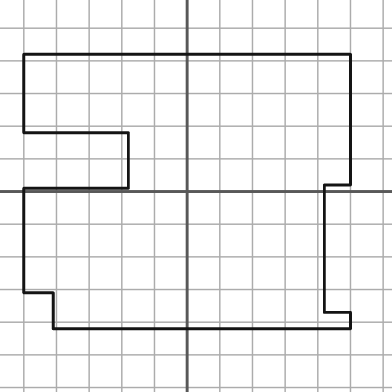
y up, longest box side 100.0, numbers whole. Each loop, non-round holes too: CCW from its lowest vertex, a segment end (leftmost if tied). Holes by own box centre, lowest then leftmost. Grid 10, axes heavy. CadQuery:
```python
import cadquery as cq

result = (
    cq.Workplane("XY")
    .moveTo(-41.0, -42.0)
    .lineTo(50.0, -42.0)
    .lineTo(50.0, -37.0)
    .lineTo(42.0, -37.0)
    .lineTo(42.0, 2.0)
    .lineTo(50.0, 2.0)
    .lineTo(50.0, 42.0)
    .lineTo(-50.0, 42.0)
    .lineTo(-50.0, 18.0)
    .lineTo(-18.0, 18.0)
    .lineTo(-18.0, 1.0)
    .lineTo(-50.0, 1.0)
    .lineTo(-50.0, -31.0)
    .lineTo(-41.0, -31.0)
    .close()
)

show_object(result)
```